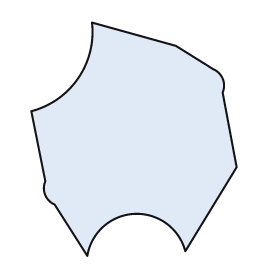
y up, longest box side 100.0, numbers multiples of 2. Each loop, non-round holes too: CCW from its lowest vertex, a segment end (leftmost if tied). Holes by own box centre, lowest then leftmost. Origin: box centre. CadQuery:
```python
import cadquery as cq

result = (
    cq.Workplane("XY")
    .moveTo(-20.0, -50.0)
    .threePointArc((0.0, -32.0), (22.0, -48.0))
    .lineTo(44.0, -12.0)
    .lineTo(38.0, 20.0)
    .threePointArc((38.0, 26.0), (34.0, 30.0))
    .lineTo(18.0, 40.0)
    .lineTo(-18.0, 50.0)
    .threePointArc((-24.0, 26.0), (-44.0, 12.0))
    .lineTo(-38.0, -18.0)
    .threePointArc((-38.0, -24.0), (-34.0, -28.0))
    .close()
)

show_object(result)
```